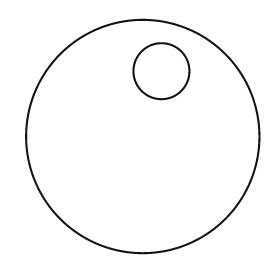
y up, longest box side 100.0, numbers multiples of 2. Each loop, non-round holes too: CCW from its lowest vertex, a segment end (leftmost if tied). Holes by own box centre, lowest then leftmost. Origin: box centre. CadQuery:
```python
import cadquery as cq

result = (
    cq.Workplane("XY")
    .moveTo(0.0, 0.0)
    .circle(50.0)
    .moveTo(8.0, 28.0)
    .circle(12.0)
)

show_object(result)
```